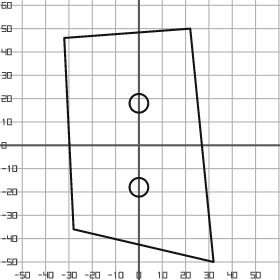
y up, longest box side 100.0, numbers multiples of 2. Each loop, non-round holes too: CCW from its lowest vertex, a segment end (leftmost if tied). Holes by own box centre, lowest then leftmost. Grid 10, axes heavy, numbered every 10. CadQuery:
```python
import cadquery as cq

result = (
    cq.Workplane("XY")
    .moveTo(32.0, -50.0)
    .lineTo(22.0, 50.0)
    .lineTo(-32.0, 46.0)
    .lineTo(-28.0, -36.0)
    .close()
    .moveTo(0.0, -18.0)
    .circle(4.0)
    .moveTo(0.0, 18.0)
    .circle(4.0)
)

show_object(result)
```